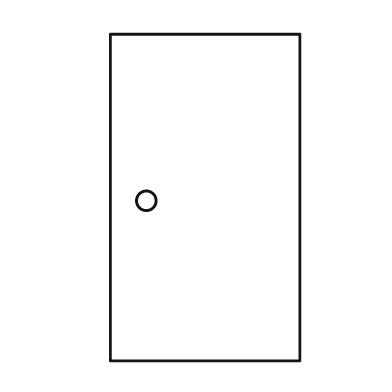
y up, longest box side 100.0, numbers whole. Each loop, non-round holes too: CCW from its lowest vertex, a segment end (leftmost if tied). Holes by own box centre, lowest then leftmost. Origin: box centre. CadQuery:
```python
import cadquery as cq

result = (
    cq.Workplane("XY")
    .moveTo(-29.0, -50.0)
    .lineTo(29.0, -50.0)
    .lineTo(29.0, 50.0)
    .lineTo(-29.0, 50.0)
    .close()
    .moveTo(-18.0, -1.0)
    .circle(3.0)
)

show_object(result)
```